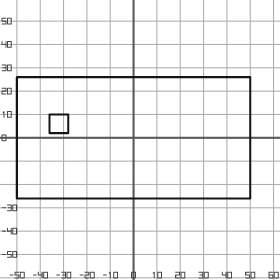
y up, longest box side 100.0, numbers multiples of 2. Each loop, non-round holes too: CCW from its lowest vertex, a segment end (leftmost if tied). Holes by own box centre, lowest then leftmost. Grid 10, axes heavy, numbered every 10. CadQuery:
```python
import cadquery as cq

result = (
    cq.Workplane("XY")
    .moveTo(-50.0, -26.0)
    .lineTo(50.0, -26.0)
    .lineTo(50.0, 26.0)
    .lineTo(-50.0, 26.0)
    .close()
    .moveTo(-36.0, 2.0)
    .lineTo(-28.0, 2.0)
    .lineTo(-28.0, 10.0)
    .lineTo(-36.0, 10.0)
    .close()
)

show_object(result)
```